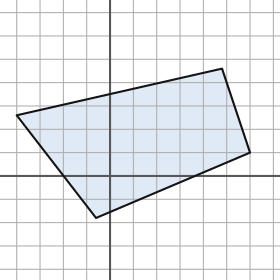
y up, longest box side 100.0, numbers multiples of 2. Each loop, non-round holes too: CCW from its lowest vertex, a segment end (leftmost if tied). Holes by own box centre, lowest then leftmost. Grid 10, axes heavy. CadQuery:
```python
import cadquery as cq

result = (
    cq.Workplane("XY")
    .moveTo(-6.0, -18.0)
    .lineTo(60.0, 10.0)
    .lineTo(48.0, 46.0)
    .lineTo(-40.0, 26.0)
    .close()
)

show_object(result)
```